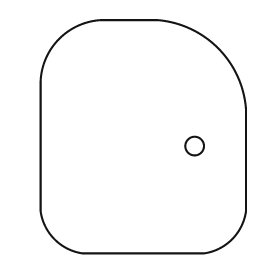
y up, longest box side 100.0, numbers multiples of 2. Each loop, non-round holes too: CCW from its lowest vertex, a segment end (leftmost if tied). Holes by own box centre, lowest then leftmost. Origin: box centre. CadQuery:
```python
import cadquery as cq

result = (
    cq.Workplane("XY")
    .moveTo(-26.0, -50.0)
    .lineTo(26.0, -50.0)
    .threePointArc((38.0, -44.0), (44.0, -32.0))
    .lineTo(44.0, 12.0)
    .threePointArc((32.0, 38.0), (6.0, 50.0))
    .lineTo(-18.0, 50.0)
    .threePointArc((-36.0, 42.0), (-44.0, 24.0))
    .lineTo(-44.0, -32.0)
    .threePointArc((-38.0, -44.0), (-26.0, -50.0))
    .close()
    .moveTo(22.0, -4.0)
    .circle(4.0)
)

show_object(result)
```